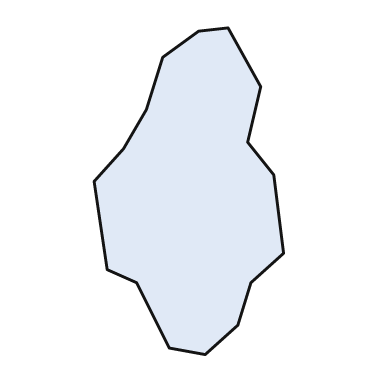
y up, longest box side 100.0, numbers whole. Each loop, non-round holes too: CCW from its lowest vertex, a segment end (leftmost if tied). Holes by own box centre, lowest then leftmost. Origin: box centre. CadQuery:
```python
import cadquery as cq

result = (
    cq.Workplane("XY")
    .moveTo(5.0, -50.0)
    .lineTo(15.0, -41.0)
    .lineTo(19.0, -28.0)
    .lineTo(29.0, -19.0)
    .lineTo(26.0, 5.0)
    .lineTo(18.0, 15.0)
    .lineTo(22.0, 32.0)
    .lineTo(12.0, 50.0)
    .lineTo(3.0, 49.0)
    .lineTo(-8.0, 41.0)
    .lineTo(-13.0, 25.0)
    .lineTo(-20.0, 13.0)
    .lineTo(-29.0, 3.0)
    .lineTo(-25.0, -24.0)
    .lineTo(-16.0, -28.0)
    .lineTo(-6.0, -48.0)
    .close()
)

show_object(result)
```